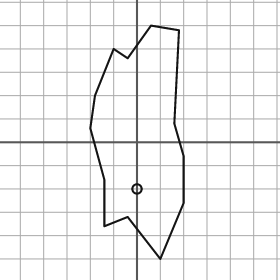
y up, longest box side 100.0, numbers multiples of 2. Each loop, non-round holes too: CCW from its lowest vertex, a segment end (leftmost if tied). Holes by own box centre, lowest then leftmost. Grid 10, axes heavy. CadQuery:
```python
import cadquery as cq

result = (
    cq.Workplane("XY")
    .moveTo(10.0, -50.0)
    .lineTo(20.0, -26.0)
    .lineTo(20.0, -6.0)
    .lineTo(16.0, 8.0)
    .lineTo(18.0, 48.0)
    .lineTo(6.0, 50.0)
    .lineTo(-4.0, 36.0)
    .lineTo(-10.0, 40.0)
    .lineTo(-18.0, 20.0)
    .lineTo(-20.0, 6.0)
    .lineTo(-14.0, -16.0)
    .lineTo(-14.0, -36.0)
    .lineTo(-4.0, -32.0)
    .close()
    .moveTo(0.0, -20.0)
    .circle(2.0)
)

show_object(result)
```